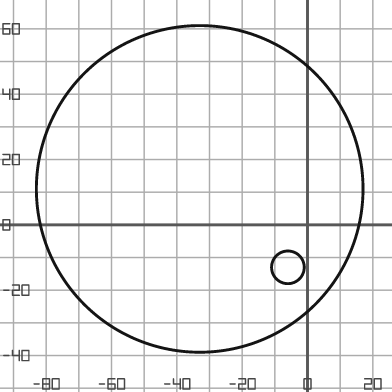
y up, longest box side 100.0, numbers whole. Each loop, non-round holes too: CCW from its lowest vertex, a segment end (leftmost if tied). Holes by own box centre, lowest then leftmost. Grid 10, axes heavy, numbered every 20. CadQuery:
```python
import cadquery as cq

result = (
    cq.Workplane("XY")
    .moveTo(-33.0, 11.0)
    .circle(50.0)
    .moveTo(-6.0, -13.0)
    .circle(5.0)
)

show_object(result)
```